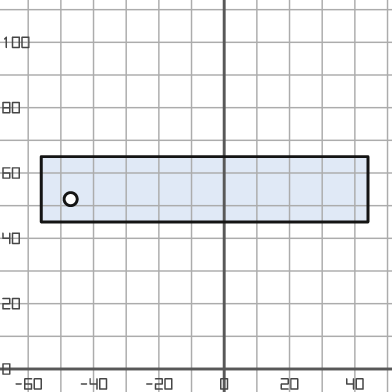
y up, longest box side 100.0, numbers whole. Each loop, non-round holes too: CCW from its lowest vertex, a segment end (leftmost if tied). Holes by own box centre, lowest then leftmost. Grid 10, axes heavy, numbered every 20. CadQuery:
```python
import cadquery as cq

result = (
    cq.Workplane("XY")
    .moveTo(-56.0, 45.0)
    .lineTo(44.0, 45.0)
    .lineTo(44.0, 65.0)
    .lineTo(-56.0, 65.0)
    .close()
    .moveTo(-47.0, 52.0)
    .circle(2.0)
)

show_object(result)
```